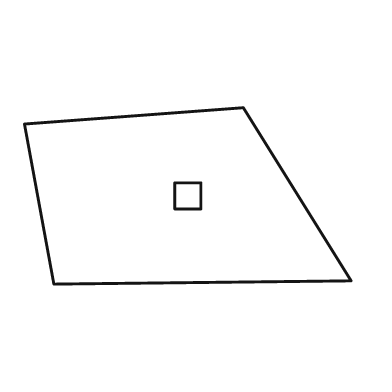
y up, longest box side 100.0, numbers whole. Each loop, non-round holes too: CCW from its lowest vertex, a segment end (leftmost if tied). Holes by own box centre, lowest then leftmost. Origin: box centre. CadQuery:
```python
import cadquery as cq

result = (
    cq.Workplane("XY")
    .moveTo(-41.0, -27.0)
    .lineTo(50.0, -26.0)
    .lineTo(17.0, 27.0)
    .lineTo(-50.0, 22.0)
    .close()
    .moveTo(-4.0, -4.0)
    .lineTo(4.0, -4.0)
    .lineTo(4.0, 4.0)
    .lineTo(-4.0, 4.0)
    .close()
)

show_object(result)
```